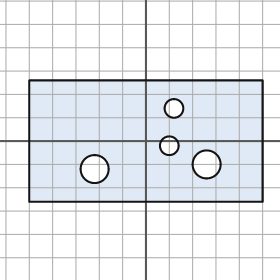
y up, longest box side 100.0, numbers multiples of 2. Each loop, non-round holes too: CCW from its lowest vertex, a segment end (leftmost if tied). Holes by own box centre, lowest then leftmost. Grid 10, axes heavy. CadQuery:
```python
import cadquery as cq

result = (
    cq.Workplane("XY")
    .moveTo(-50.0, -26.0)
    .lineTo(50.0, -26.0)
    .lineTo(50.0, 26.0)
    .lineTo(-50.0, 26.0)
    .close()
    .moveTo(-22.0, -12.0)
    .circle(6.0)
    .moveTo(26.0, -10.0)
    .circle(6.0)
    .moveTo(10.0, -2.0)
    .circle(4.0)
    .moveTo(12.0, 14.0)
    .circle(4.0)
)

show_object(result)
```